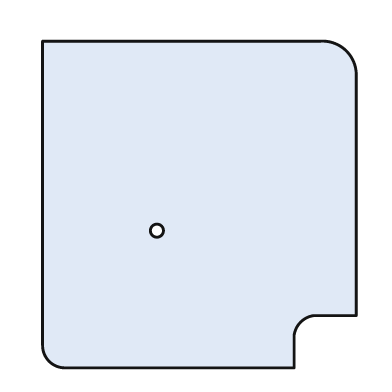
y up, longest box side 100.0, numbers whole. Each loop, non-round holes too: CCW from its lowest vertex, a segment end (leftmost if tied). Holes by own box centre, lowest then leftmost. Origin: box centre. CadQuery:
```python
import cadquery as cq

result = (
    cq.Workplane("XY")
    .moveTo(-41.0, -50.0)
    .lineTo(29.0, -50.0)
    .lineTo(29.0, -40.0)
    .threePointArc((31.0, -36.0), (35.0, -34.0))
    .lineTo(48.0, -34.0)
    .lineTo(48.0, 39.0)
    .threePointArc((45.0, 47.0), (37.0, 50.0))
    .lineTo(-48.0, 50.0)
    .lineTo(-48.0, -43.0)
    .threePointArc((-46.0, -48.0), (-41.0, -50.0))
    .close()
    .moveTo(-13.0, -8.0)
    .circle(2.0)
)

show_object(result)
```